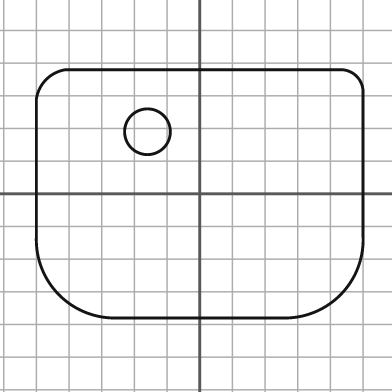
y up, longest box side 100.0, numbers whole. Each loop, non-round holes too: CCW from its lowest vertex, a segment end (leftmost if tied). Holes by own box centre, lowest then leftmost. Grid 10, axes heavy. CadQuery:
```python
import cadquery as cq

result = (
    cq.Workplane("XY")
    .moveTo(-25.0, -38.0)
    .lineTo(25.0, -38.0)
    .threePointArc((43.0, -31.0), (50.0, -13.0))
    .lineTo(50.0, 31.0)
    .threePointArc((48.0, 36.0), (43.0, 38.0))
    .lineTo(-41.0, 38.0)
    .threePointArc((-47.0, 35.0), (-50.0, 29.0))
    .lineTo(-50.0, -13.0)
    .threePointArc((-43.0, -31.0), (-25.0, -38.0))
    .close()
    .moveTo(-16.0, 19.0)
    .circle(7.0)
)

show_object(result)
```